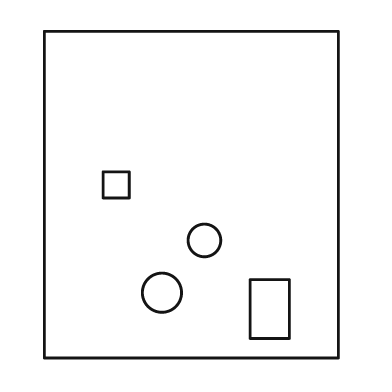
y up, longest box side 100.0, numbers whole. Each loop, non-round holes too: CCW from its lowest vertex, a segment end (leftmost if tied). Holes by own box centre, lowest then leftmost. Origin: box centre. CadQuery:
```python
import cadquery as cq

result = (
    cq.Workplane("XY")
    .moveTo(-45.0, -50.0)
    .lineTo(45.0, -50.0)
    .lineTo(45.0, 50.0)
    .lineTo(-45.0, 50.0)
    .close()
    .moveTo(18.0, -44.0)
    .lineTo(30.0, -44.0)
    .lineTo(30.0, -26.0)
    .lineTo(18.0, -26.0)
    .close()
    .moveTo(-9.0, -30.0)
    .circle(6.0)
    .moveTo(4.0, -14.0)
    .circle(5.0)
    .moveTo(-27.0, -1.0)
    .lineTo(-19.0, -1.0)
    .lineTo(-19.0, 7.0)
    .lineTo(-27.0, 7.0)
    .close()
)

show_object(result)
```